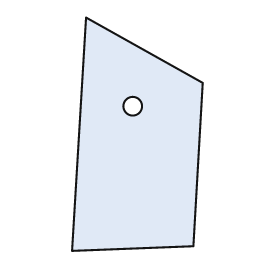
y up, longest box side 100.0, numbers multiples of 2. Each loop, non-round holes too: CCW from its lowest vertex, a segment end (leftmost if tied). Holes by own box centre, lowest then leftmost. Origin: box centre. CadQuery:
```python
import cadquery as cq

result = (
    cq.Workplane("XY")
    .moveTo(-28.0, -50.0)
    .lineTo(24.0, -48.0)
    .lineTo(28.0, 22.0)
    .lineTo(-22.0, 50.0)
    .close()
    .moveTo(-2.0, 12.0)
    .circle(4.0)
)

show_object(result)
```